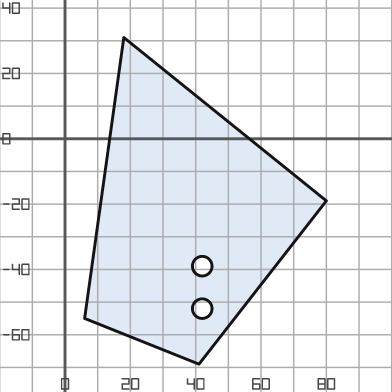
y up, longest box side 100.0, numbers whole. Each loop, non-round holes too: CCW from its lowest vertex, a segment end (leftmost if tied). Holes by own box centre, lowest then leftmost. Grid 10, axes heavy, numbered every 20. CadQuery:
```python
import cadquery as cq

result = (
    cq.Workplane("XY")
    .moveTo(41.0, -69.0)
    .lineTo(80.0, -19.0)
    .lineTo(18.0, 31.0)
    .lineTo(6.0, -55.0)
    .close()
    .moveTo(42.0, -52.0)
    .circle(3.0)
    .moveTo(42.0, -39.0)
    .circle(3.0)
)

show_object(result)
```